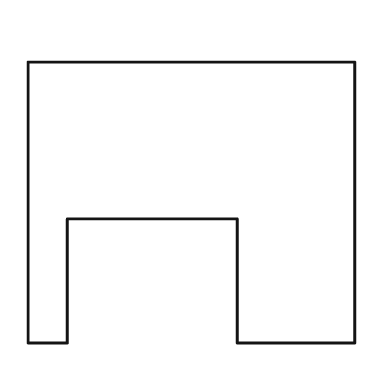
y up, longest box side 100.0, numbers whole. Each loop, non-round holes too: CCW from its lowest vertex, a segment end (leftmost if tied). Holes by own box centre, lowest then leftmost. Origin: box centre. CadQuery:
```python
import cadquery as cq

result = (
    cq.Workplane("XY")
    .moveTo(-50.0, -43.0)
    .lineTo(-38.0, -43.0)
    .lineTo(-38.0, -5.0)
    .lineTo(14.0, -5.0)
    .lineTo(14.0, -43.0)
    .lineTo(50.0, -43.0)
    .lineTo(50.0, 43.0)
    .lineTo(-50.0, 43.0)
    .close()
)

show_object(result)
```